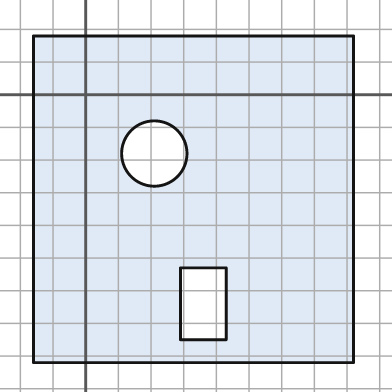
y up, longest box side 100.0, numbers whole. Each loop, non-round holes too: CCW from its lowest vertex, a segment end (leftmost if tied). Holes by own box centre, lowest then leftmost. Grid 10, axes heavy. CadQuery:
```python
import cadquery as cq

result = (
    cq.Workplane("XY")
    .moveTo(-16.0, -82.0)
    .lineTo(82.0, -82.0)
    .lineTo(82.0, 18.0)
    .lineTo(-16.0, 18.0)
    .close()
    .moveTo(29.0, -75.0)
    .lineTo(43.0, -75.0)
    .lineTo(43.0, -53.0)
    .lineTo(29.0, -53.0)
    .close()
    .moveTo(21.0, -18.0)
    .circle(10.0)
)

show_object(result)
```